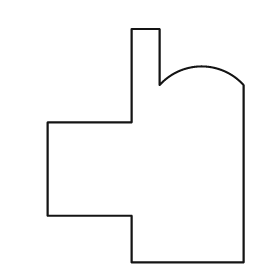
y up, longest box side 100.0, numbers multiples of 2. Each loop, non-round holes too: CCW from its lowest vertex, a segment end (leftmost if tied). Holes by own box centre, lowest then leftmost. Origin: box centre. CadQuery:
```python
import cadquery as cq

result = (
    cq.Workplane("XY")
    .moveTo(-6.0, -50.0)
    .lineTo(42.0, -50.0)
    .lineTo(42.0, 26.0)
    .threePointArc((24.0, 34.0), (6.0, 26.0))
    .lineTo(6.0, 50.0)
    .lineTo(-6.0, 50.0)
    .lineTo(-6.0, 10.0)
    .lineTo(-42.0, 10.0)
    .lineTo(-42.0, -30.0)
    .lineTo(-6.0, -30.0)
    .close()
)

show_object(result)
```